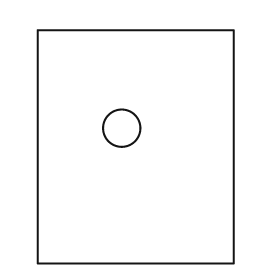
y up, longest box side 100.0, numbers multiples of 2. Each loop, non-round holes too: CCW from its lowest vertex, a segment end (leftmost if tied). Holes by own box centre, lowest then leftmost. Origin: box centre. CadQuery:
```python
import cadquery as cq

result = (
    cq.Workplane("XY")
    .moveTo(-42.0, -50.0)
    .lineTo(42.0, -50.0)
    .lineTo(42.0, 50.0)
    .lineTo(-42.0, 50.0)
    .close()
    .moveTo(-6.0, 8.0)
    .circle(8.0)
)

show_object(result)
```